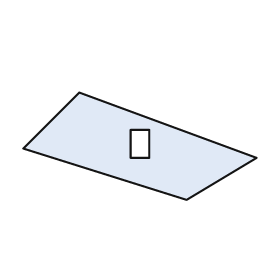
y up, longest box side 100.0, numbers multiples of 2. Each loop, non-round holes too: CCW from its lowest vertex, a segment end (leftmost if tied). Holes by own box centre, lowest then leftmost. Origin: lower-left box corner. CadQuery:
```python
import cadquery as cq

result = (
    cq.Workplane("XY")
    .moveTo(70.0, 0.0)
    .lineTo(100.0, 18.0)
    .lineTo(24.0, 46.0)
    .lineTo(0.0, 22.0)
    .close()
    .moveTo(46.0, 18.0)
    .lineTo(54.0, 18.0)
    .lineTo(54.0, 30.0)
    .lineTo(46.0, 30.0)
    .close()
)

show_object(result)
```